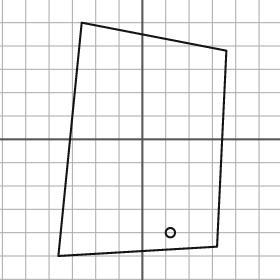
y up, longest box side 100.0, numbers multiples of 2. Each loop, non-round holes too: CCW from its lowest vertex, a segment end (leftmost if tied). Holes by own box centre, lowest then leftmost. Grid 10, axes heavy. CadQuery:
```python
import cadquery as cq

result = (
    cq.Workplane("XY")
    .moveTo(-36.0, -50.0)
    .lineTo(32.0, -46.0)
    .lineTo(36.0, 38.0)
    .lineTo(-26.0, 50.0)
    .close()
    .moveTo(12.0, -40.0)
    .circle(2.0)
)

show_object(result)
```